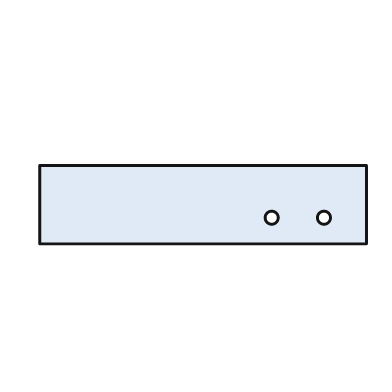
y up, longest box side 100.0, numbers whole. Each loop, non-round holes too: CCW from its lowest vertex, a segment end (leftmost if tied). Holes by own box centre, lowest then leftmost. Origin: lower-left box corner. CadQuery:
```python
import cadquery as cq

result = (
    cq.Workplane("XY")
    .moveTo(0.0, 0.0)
    .lineTo(100.0, 0.0)
    .lineTo(100.0, 24.0)
    .lineTo(0.0, 24.0)
    .close()
    .moveTo(71.0, 8.0)
    .circle(2.0)
    .moveTo(87.0, 8.0)
    .circle(2.0)
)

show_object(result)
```